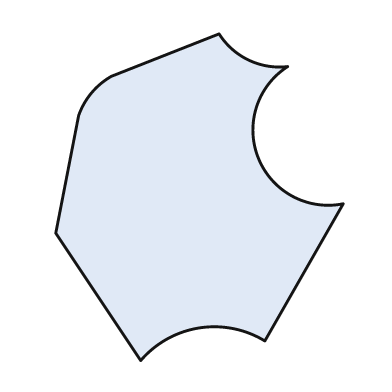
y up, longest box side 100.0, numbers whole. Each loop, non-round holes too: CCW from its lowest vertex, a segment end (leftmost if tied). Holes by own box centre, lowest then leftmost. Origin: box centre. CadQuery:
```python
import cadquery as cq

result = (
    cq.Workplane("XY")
    .moveTo(-18.0, -50.0)
    .threePointArc((0.0, -40.0), (20.0, -44.0))
    .lineTo(44.0, -2.0)
    .threePointArc((18.0, 12.0), (27.0, 40.0))
    .threePointArc((15.0, 42.0), (6.0, 50.0))
    .lineTo(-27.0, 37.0)
    .threePointArc((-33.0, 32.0), (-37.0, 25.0))
    .lineTo(-44.0, -11.0)
    .close()
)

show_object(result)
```